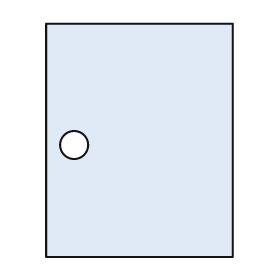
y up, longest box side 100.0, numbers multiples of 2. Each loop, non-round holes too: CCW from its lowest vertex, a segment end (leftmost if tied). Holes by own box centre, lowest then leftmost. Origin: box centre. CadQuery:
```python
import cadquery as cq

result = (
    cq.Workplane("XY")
    .moveTo(-40.0, -50.0)
    .lineTo(40.0, -50.0)
    .lineTo(40.0, 50.0)
    .lineTo(-40.0, 50.0)
    .close()
    .moveTo(-28.0, -2.0)
    .circle(6.0)
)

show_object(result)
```